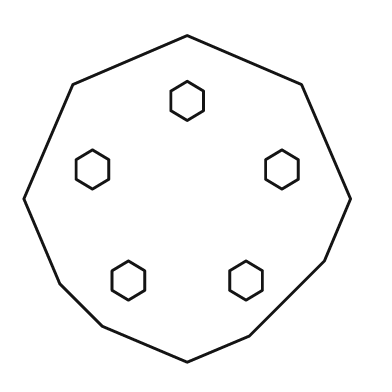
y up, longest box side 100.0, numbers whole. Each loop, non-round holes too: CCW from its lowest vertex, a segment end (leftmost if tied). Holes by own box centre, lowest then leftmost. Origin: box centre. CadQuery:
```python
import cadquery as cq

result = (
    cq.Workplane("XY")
    .moveTo(0.0, -50.0)
    .lineTo(19.0, -42.0)
    .lineTo(42.0, -19.0)
    .lineTo(50.0, 0.0)
    .lineTo(35.0, 35.0)
    .lineTo(0.0, 50.0)
    .lineTo(-35.0, 35.0)
    .lineTo(-50.0, 0.0)
    .lineTo(-39.0, -26.0)
    .lineTo(-26.0, -39.0)
    .close()
    .moveTo(-18.0, -31.0)
    .lineTo(-13.0, -28.0)
    .lineTo(-13.0, -22.0)
    .lineTo(-18.0, -19.0)
    .lineTo(-23.0, -22.0)
    .lineTo(-23.0, -28.0)
    .close()
    .moveTo(18.0, -31.0)
    .lineTo(23.0, -28.0)
    .lineTo(23.0, -22.0)
    .lineTo(18.0, -19.0)
    .lineTo(13.0, -22.0)
    .lineTo(13.0, -28.0)
    .close()
    .moveTo(-29.0, 3.0)
    .lineTo(-24.0, 6.0)
    .lineTo(-24.0, 12.0)
    .lineTo(-29.0, 15.0)
    .lineTo(-34.0, 12.0)
    .lineTo(-34.0, 6.0)
    .close()
    .moveTo(29.0, 3.0)
    .lineTo(34.0, 6.0)
    .lineTo(34.0, 12.0)
    .lineTo(29.0, 15.0)
    .lineTo(24.0, 12.0)
    .lineTo(24.0, 6.0)
    .close()
    .moveTo(0.0, 24.0)
    .lineTo(5.0, 27.0)
    .lineTo(5.0, 33.0)
    .lineTo(0.0, 36.0)
    .lineTo(-5.0, 33.0)
    .lineTo(-5.0, 27.0)
    .close()
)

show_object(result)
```